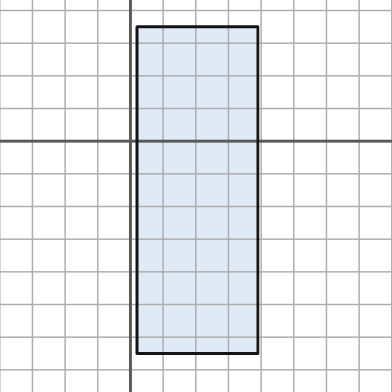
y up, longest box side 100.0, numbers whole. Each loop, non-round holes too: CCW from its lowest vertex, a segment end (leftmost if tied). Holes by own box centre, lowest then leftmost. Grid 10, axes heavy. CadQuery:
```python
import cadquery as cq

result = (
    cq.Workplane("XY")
    .moveTo(2.0, -65.0)
    .lineTo(39.0, -65.0)
    .lineTo(39.0, 35.0)
    .lineTo(2.0, 35.0)
    .close()
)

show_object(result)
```